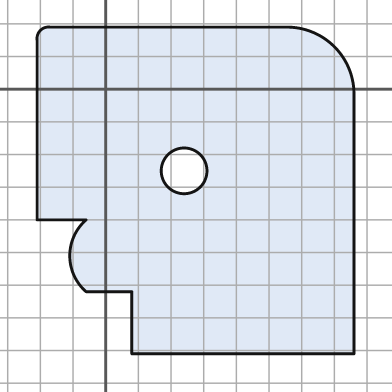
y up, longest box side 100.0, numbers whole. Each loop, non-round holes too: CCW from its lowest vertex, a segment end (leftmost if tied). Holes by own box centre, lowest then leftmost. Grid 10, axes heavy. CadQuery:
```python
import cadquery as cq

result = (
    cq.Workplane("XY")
    .moveTo(8.0, -81.0)
    .lineTo(76.0, -81.0)
    .lineTo(76.0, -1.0)
    .threePointArc((70.0, 13.0), (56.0, 19.0))
    .lineTo(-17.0, 19.0)
    .threePointArc((-20.0, 18.0), (-21.0, 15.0))
    .lineTo(-21.0, -40.0)
    .lineTo(-6.0, -40.0)
    .threePointArc((-11.0, -51.0), (-6.0, -62.0))
    .lineTo(8.0, -62.0)
    .close()
    .moveTo(24.0, -25.0)
    .circle(7.0)
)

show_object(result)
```